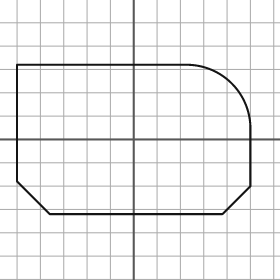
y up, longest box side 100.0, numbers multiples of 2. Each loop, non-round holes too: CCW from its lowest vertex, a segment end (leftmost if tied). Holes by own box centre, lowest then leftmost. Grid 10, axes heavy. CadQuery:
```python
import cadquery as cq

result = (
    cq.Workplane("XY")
    .moveTo(-36.0, -32.0)
    .lineTo(38.0, -32.0)
    .lineTo(50.0, -20.0)
    .lineTo(50.0, 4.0)
    .threePointArc((42.0, 24.0), (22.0, 32.0))
    .lineTo(-50.0, 32.0)
    .lineTo(-50.0, -18.0)
    .close()
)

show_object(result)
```